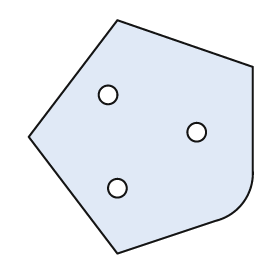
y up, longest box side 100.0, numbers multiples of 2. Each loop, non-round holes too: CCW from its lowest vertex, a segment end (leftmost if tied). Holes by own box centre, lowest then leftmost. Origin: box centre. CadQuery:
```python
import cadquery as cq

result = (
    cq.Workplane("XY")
    .moveTo(-10.0, -50.0)
    .lineTo(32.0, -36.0)
    .threePointArc((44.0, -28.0), (48.0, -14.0))
    .lineTo(48.0, 30.0)
    .lineTo(-10.0, 50.0)
    .lineTo(-48.0, 0.0)
    .close()
    .moveTo(-10.0, -22.0)
    .circle(4.0)
    .moveTo(24.0, 2.0)
    .circle(4.0)
    .moveTo(-14.0, 18.0)
    .circle(4.0)
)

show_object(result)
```